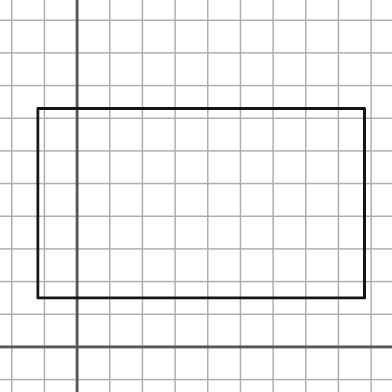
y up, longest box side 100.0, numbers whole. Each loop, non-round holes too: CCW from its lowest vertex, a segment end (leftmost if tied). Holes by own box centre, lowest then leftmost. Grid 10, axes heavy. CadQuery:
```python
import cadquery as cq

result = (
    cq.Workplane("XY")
    .moveTo(-12.0, 15.0)
    .lineTo(88.0, 15.0)
    .lineTo(88.0, 73.0)
    .lineTo(-12.0, 73.0)
    .close()
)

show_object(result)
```